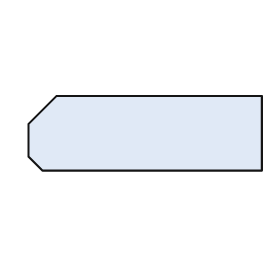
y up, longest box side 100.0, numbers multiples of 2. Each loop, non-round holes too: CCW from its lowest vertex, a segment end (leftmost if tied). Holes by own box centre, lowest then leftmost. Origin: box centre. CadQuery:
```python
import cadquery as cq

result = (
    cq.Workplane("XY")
    .moveTo(-44.0, -16.0)
    .lineTo(50.0, -16.0)
    .lineTo(50.0, 16.0)
    .lineTo(-38.0, 16.0)
    .lineTo(-50.0, 4.0)
    .lineTo(-50.0, -10.0)
    .close()
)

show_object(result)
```